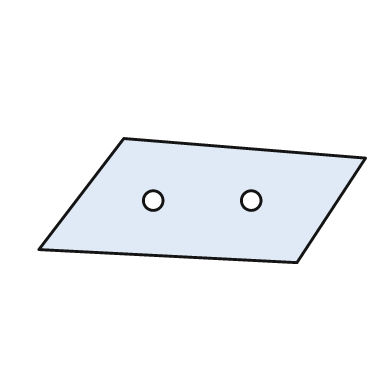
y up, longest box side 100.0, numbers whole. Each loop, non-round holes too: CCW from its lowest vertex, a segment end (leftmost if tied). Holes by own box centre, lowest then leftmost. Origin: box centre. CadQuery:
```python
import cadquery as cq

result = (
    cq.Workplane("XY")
    .moveTo(29.0, -19.0)
    .lineTo(50.0, 13.0)
    .lineTo(-24.0, 19.0)
    .lineTo(-50.0, -15.0)
    .close()
    .moveTo(-15.0, 0.0)
    .circle(3.0)
    .moveTo(15.0, 0.0)
    .circle(3.0)
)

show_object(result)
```